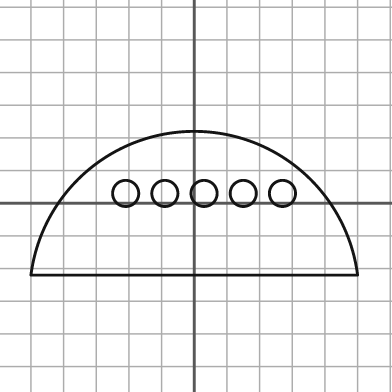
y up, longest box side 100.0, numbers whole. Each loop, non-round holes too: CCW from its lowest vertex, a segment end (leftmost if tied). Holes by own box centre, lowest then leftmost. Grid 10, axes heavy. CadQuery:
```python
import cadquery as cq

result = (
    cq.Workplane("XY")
    .moveTo(-50.0, -22.0)
    .lineTo(50.0, -22.0)
    .threePointArc((0.0, 22.0), (-50.0, -22.0))
    .close()
    .moveTo(-21.0, 3.0)
    .circle(4.0)
    .moveTo(-9.0, 3.0)
    .circle(4.0)
    .moveTo(3.0, 3.0)
    .circle(4.0)
    .moveTo(15.0, 3.0)
    .circle(4.0)
    .moveTo(27.0, 3.0)
    .circle(4.0)
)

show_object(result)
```